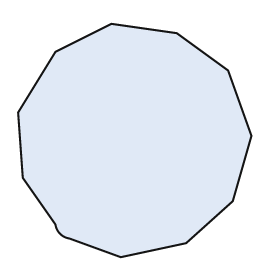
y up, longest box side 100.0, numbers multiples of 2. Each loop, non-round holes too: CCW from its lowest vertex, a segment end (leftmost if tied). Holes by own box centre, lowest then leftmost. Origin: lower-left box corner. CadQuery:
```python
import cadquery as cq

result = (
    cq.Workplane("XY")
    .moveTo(44.0, 0.0)
    .lineTo(72.0, 6.0)
    .lineTo(92.0, 24.0)
    .lineTo(100.0, 52.0)
    .lineTo(90.0, 80.0)
    .lineTo(68.0, 96.0)
    .lineTo(40.0, 100.0)
    .lineTo(16.0, 88.0)
    .lineTo(0.0, 62.0)
    .lineTo(2.0, 34.0)
    .lineTo(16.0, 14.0)
    .threePointArc((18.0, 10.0), (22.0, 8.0))
    .close()
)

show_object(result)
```